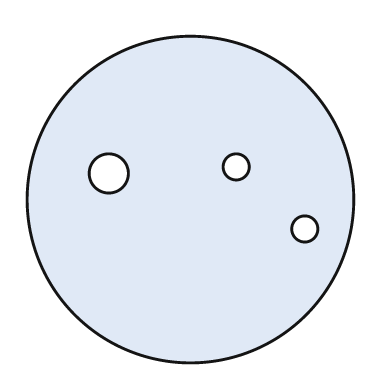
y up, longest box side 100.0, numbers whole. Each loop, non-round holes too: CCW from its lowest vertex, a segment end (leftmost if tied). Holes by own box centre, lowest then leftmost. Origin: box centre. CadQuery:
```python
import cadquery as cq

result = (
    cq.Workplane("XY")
    .moveTo(0.0, 0.0)
    .circle(50.0)
    .moveTo(35.0, -9.0)
    .circle(4.0)
    .moveTo(-25.0, 8.0)
    .circle(6.0)
    .moveTo(14.0, 10.0)
    .circle(4.0)
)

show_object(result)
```